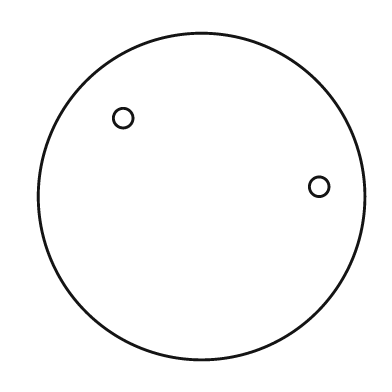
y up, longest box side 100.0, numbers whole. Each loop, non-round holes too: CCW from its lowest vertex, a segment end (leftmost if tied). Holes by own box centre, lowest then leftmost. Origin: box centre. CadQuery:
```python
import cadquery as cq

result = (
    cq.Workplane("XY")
    .moveTo(0.0, 0.0)
    .circle(50.0)
    .moveTo(36.0, 3.0)
    .circle(3.0)
    .moveTo(-24.0, 24.0)
    .circle(3.0)
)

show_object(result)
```